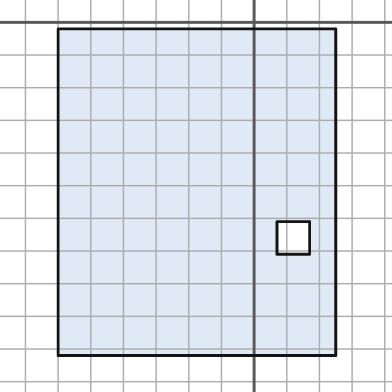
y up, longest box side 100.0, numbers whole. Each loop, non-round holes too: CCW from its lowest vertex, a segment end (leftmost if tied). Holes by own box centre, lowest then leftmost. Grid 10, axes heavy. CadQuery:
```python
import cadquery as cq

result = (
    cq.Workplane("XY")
    .moveTo(-60.0, -102.0)
    .lineTo(25.0, -102.0)
    .lineTo(25.0, -2.0)
    .lineTo(-60.0, -2.0)
    .close()
    .moveTo(7.0, -71.0)
    .lineTo(17.0, -71.0)
    .lineTo(17.0, -61.0)
    .lineTo(7.0, -61.0)
    .close()
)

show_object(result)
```